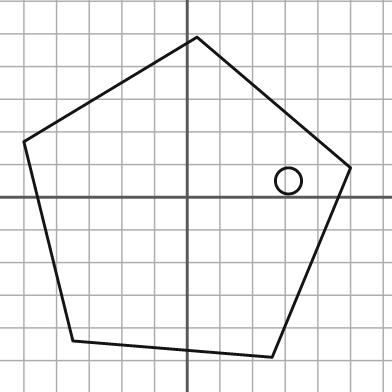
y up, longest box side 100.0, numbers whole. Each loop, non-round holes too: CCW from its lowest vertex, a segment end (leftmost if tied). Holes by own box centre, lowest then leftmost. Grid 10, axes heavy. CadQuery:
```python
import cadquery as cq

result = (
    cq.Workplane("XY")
    .moveTo(26.0, -49.0)
    .lineTo(50.0, 9.0)
    .lineTo(3.0, 49.0)
    .lineTo(-50.0, 17.0)
    .lineTo(-35.0, -44.0)
    .close()
    .moveTo(31.0, 5.0)
    .circle(4.0)
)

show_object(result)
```